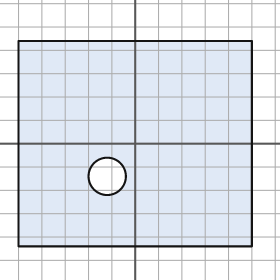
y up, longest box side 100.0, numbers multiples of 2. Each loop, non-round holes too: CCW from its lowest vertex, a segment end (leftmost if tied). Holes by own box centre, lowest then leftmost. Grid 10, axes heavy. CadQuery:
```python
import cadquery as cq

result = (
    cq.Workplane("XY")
    .moveTo(-50.0, -44.0)
    .lineTo(50.0, -44.0)
    .lineTo(50.0, 44.0)
    .lineTo(-50.0, 44.0)
    .close()
    .moveTo(-12.0, -14.0)
    .circle(8.0)
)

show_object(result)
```